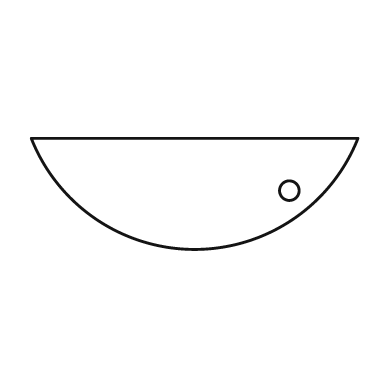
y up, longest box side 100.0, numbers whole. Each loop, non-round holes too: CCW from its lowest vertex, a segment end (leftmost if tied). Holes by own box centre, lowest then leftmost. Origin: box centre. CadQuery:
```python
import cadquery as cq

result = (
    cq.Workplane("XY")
    .moveTo(-50.0, 17.0)
    .threePointArc((0.0, -17.0), (50.0, 17.0))
    .close()
    .moveTo(29.0, 1.0)
    .circle(3.0)
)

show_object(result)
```